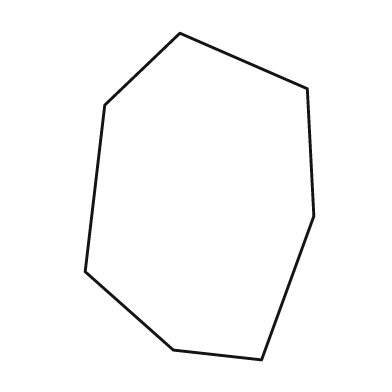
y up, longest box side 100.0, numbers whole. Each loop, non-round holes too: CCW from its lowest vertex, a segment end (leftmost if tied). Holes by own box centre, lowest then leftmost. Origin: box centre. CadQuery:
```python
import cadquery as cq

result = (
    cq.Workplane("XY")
    .moveTo(19.0, -50.0)
    .lineTo(35.0, -6.0)
    .lineTo(33.0, 33.0)
    .lineTo(-6.0, 50.0)
    .lineTo(-29.0, 28.0)
    .lineTo(-35.0, -23.0)
    .lineTo(-8.0, -47.0)
    .close()
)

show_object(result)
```